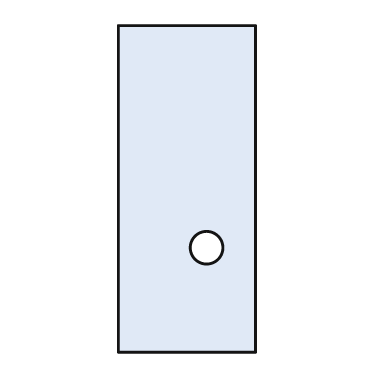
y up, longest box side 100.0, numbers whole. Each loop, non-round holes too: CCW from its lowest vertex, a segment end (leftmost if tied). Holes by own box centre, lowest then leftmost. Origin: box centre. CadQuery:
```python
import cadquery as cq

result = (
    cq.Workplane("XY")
    .moveTo(-21.0, -50.0)
    .lineTo(21.0, -50.0)
    .lineTo(21.0, 50.0)
    .lineTo(-21.0, 50.0)
    .close()
    .moveTo(6.0, -18.0)
    .circle(5.0)
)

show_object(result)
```